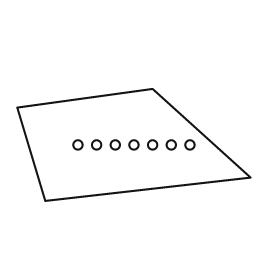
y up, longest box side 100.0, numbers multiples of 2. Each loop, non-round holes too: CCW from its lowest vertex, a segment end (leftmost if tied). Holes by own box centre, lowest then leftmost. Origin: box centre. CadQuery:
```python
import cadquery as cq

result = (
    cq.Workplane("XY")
    .moveTo(-38.0, -24.0)
    .lineTo(50.0, -14.0)
    .lineTo(8.0, 24.0)
    .lineTo(-50.0, 16.0)
    .close()
    .moveTo(-24.0, 0.0)
    .circle(2.0)
    .moveTo(-16.0, 0.0)
    .circle(2.0)
    .moveTo(-8.0, 0.0)
    .circle(2.0)
    .moveTo(0.0, 0.0)
    .circle(2.0)
    .moveTo(8.0, 0.0)
    .circle(2.0)
    .moveTo(16.0, 0.0)
    .circle(2.0)
    .moveTo(24.0, 0.0)
    .circle(2.0)
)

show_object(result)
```